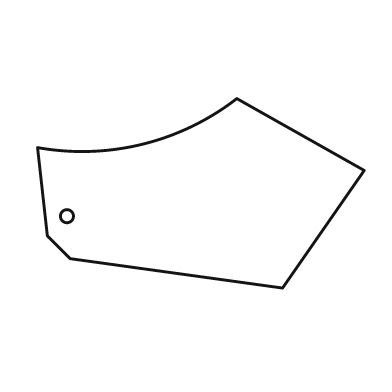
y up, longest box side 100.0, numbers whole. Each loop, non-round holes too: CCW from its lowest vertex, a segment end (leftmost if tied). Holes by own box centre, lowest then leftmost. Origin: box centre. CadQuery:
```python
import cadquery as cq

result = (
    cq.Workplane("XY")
    .moveTo(25.0, -29.0)
    .lineTo(50.0, 7.0)
    .lineTo(11.0, 29.0)
    .threePointArc((-18.0, 15.0), (-50.0, 14.0))
    .lineTo(-47.0, -13.0)
    .lineTo(-40.0, -20.0)
    .close()
    .moveTo(-41.0, -7.0)
    .circle(2.0)
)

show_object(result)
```